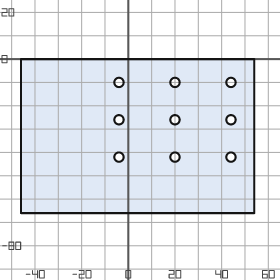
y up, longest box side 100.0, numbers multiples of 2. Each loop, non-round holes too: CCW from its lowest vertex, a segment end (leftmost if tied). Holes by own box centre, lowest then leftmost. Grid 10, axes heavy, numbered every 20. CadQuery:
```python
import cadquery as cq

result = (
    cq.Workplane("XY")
    .moveTo(-46.0, -66.0)
    .lineTo(54.0, -66.0)
    .lineTo(54.0, 0.0)
    .lineTo(-46.0, 0.0)
    .close()
    .moveTo(-4.0, -42.0)
    .circle(2.0)
    .moveTo(20.0, -42.0)
    .circle(2.0)
    .moveTo(44.0, -42.0)
    .circle(2.0)
    .moveTo(-4.0, -26.0)
    .circle(2.0)
    .moveTo(20.0, -26.0)
    .circle(2.0)
    .moveTo(44.0, -26.0)
    .circle(2.0)
    .moveTo(-4.0, -10.0)
    .circle(2.0)
    .moveTo(20.0, -10.0)
    .circle(2.0)
    .moveTo(44.0, -10.0)
    .circle(2.0)
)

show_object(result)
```